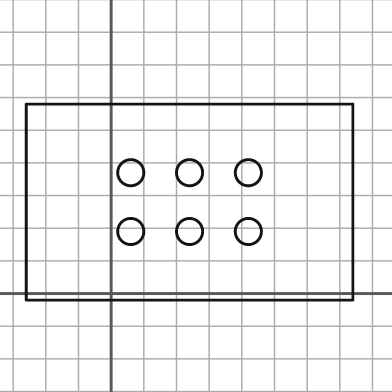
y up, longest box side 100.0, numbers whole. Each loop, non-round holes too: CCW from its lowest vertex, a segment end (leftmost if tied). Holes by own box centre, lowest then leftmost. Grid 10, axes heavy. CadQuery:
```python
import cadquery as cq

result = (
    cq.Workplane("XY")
    .moveTo(-26.0, -2.0)
    .lineTo(74.0, -2.0)
    .lineTo(74.0, 58.0)
    .lineTo(-26.0, 58.0)
    .close()
    .moveTo(6.0, 19.0)
    .circle(4.0)
    .moveTo(24.0, 19.0)
    .circle(4.0)
    .moveTo(42.0, 19.0)
    .circle(4.0)
    .moveTo(6.0, 37.0)
    .circle(4.0)
    .moveTo(24.0, 37.0)
    .circle(4.0)
    .moveTo(42.0, 37.0)
    .circle(4.0)
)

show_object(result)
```